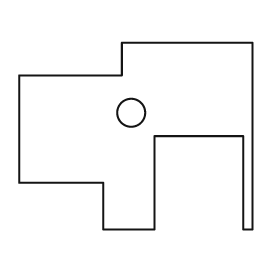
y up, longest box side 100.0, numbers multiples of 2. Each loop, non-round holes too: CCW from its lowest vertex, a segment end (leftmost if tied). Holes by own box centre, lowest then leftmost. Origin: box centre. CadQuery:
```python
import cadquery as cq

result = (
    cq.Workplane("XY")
    .moveTo(-14.0, -40.0)
    .lineTo(8.0, -40.0)
    .lineTo(8.0, 0.0)
    .lineTo(46.0, 0.0)
    .lineTo(46.0, -40.0)
    .lineTo(50.0, -40.0)
    .lineTo(50.0, 40.0)
    .lineTo(-6.0, 40.0)
    .lineTo(-6.0, 26.0)
    .lineTo(-50.0, 26.0)
    .lineTo(-50.0, -20.0)
    .lineTo(-14.0, -20.0)
    .close()
    .moveTo(-2.0, 10.0)
    .circle(6.0)
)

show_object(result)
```